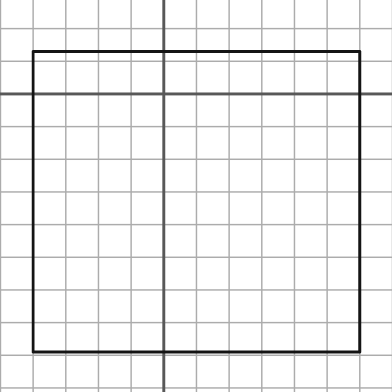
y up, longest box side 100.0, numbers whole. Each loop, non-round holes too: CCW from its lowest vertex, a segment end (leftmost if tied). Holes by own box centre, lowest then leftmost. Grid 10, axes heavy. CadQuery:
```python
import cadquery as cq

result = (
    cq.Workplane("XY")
    .moveTo(-40.0, -79.0)
    .lineTo(60.0, -79.0)
    .lineTo(60.0, 13.0)
    .lineTo(-40.0, 13.0)
    .close()
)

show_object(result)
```